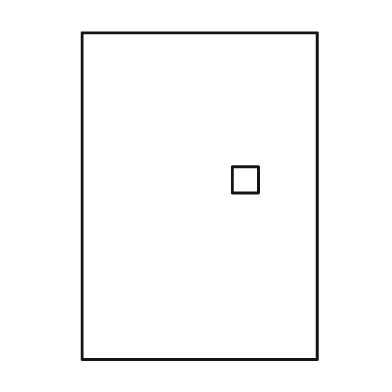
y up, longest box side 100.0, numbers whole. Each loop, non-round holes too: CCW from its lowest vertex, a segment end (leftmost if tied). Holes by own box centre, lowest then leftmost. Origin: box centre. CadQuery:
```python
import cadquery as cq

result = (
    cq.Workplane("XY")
    .moveTo(-36.0, -50.0)
    .lineTo(36.0, -50.0)
    .lineTo(36.0, 50.0)
    .lineTo(-36.0, 50.0)
    .close()
    .moveTo(10.0, 1.0)
    .lineTo(18.0, 1.0)
    .lineTo(18.0, 9.0)
    .lineTo(10.0, 9.0)
    .close()
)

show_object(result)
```